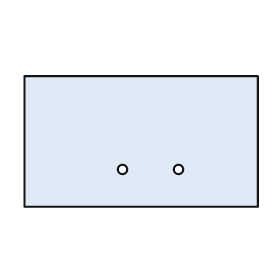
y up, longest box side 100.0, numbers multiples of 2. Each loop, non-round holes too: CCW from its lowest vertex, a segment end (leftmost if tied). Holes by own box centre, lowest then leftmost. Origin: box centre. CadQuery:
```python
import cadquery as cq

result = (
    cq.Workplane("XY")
    .moveTo(-50.0, -28.0)
    .lineTo(50.0, -28.0)
    .lineTo(50.0, 28.0)
    .lineTo(-50.0, 28.0)
    .close()
    .moveTo(-8.0, -12.0)
    .circle(2.0)
    .moveTo(16.0, -12.0)
    .circle(2.0)
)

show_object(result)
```